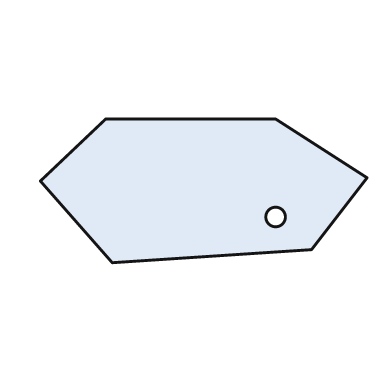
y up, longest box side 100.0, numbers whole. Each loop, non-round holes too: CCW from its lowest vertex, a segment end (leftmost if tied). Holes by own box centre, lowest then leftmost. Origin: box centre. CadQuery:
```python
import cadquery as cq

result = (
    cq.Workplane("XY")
    .moveTo(-28.0, -22.0)
    .lineTo(33.0, -18.0)
    .lineTo(50.0, 4.0)
    .lineTo(22.0, 22.0)
    .lineTo(-30.0, 22.0)
    .lineTo(-50.0, 3.0)
    .close()
    .moveTo(22.0, -8.0)
    .circle(3.0)
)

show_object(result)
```